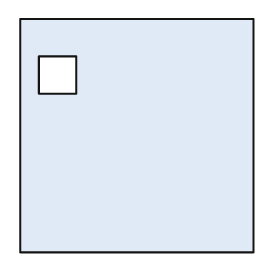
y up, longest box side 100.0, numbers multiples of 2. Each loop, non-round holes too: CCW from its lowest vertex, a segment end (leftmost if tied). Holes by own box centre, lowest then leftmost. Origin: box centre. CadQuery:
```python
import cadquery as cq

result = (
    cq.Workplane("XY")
    .moveTo(-50.0, -50.0)
    .lineTo(50.0, -50.0)
    .lineTo(50.0, 50.0)
    .lineTo(-50.0, 50.0)
    .close()
    .moveTo(-42.0, 18.0)
    .lineTo(-26.0, 18.0)
    .lineTo(-26.0, 34.0)
    .lineTo(-42.0, 34.0)
    .close()
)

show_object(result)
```